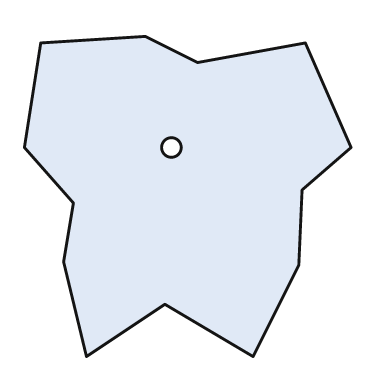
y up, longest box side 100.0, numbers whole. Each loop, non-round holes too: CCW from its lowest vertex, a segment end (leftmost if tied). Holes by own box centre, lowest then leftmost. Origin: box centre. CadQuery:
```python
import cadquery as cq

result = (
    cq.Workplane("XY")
    .moveTo(-31.0, -49.0)
    .lineTo(-7.0, -33.0)
    .lineTo(20.0, -49.0)
    .lineTo(34.0, -21.0)
    .lineTo(35.0, 2.0)
    .lineTo(50.0, 15.0)
    .lineTo(36.0, 47.0)
    .lineTo(3.0, 41.0)
    .lineTo(-13.0, 49.0)
    .lineTo(-45.0, 47.0)
    .lineTo(-50.0, 15.0)
    .lineTo(-35.0, -2.0)
    .lineTo(-38.0, -20.0)
    .close()
    .moveTo(-5.0, 15.0)
    .circle(3.0)
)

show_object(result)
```